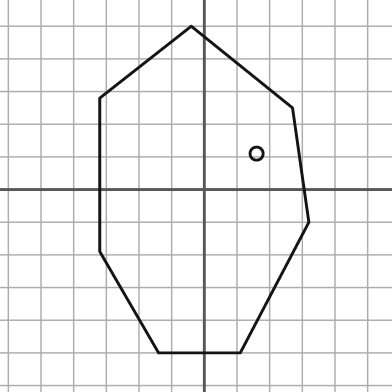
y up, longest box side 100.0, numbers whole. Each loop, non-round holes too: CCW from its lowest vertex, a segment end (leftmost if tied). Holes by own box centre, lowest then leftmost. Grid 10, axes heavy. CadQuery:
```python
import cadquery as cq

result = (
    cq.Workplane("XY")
    .moveTo(-14.0, -50.0)
    .lineTo(11.0, -50.0)
    .lineTo(32.0, -10.0)
    .lineTo(27.0, 25.0)
    .lineTo(-4.0, 50.0)
    .lineTo(-32.0, 28.0)
    .lineTo(-32.0, -19.0)
    .close()
    .moveTo(16.0, 11.0)
    .circle(2.0)
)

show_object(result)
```